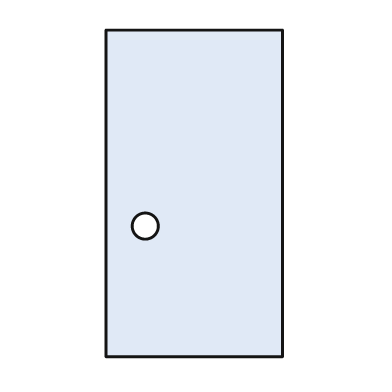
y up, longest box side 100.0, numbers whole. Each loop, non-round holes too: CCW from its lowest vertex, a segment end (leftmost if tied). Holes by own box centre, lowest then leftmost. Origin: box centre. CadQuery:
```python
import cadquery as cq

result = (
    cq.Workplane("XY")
    .moveTo(-27.0, -50.0)
    .lineTo(27.0, -50.0)
    .lineTo(27.0, 50.0)
    .lineTo(-27.0, 50.0)
    .close()
    .moveTo(-15.0, -10.0)
    .circle(4.0)
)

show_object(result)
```